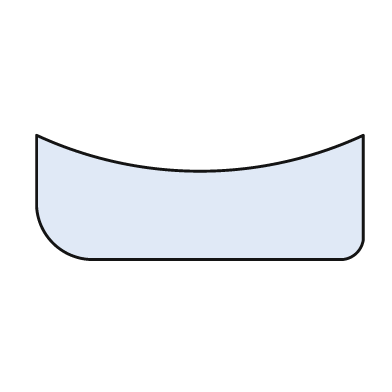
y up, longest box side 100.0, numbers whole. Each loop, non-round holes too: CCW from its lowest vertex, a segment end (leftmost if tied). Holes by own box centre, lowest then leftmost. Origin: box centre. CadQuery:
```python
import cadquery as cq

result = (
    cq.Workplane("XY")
    .moveTo(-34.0, -19.0)
    .lineTo(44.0, -19.0)
    .threePointArc((48.0, -17.0), (50.0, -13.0))
    .lineTo(50.0, 19.0)
    .threePointArc((0.0, 8.0), (-50.0, 19.0))
    .lineTo(-50.0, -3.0)
    .threePointArc((-45.0, -14.0), (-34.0, -19.0))
    .close()
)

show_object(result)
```